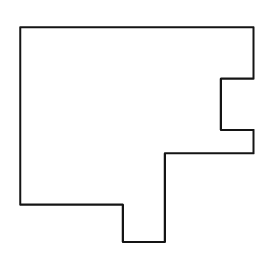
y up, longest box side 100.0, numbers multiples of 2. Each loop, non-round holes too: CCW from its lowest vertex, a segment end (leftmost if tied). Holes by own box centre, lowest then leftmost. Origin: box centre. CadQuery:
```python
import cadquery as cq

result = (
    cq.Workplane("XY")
    .moveTo(-6.0, -46.0)
    .lineTo(12.0, -46.0)
    .lineTo(12.0, -8.0)
    .lineTo(50.0, -8.0)
    .lineTo(50.0, 2.0)
    .lineTo(36.0, 2.0)
    .lineTo(36.0, 24.0)
    .lineTo(50.0, 24.0)
    .lineTo(50.0, 46.0)
    .lineTo(-50.0, 46.0)
    .lineTo(-50.0, -30.0)
    .lineTo(-6.0, -30.0)
    .close()
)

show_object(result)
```